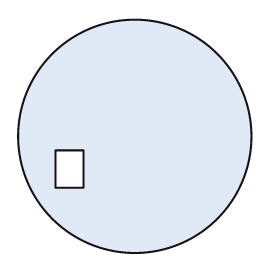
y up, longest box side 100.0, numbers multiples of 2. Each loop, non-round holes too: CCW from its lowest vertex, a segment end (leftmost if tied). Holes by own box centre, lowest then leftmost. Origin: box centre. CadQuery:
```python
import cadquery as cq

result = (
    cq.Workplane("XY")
    .moveTo(0.0, 0.0)
    .circle(50.0)
    .moveTo(-34.0, -22.0)
    .lineTo(-22.0, -22.0)
    .lineTo(-22.0, -6.0)
    .lineTo(-34.0, -6.0)
    .close()
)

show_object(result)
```